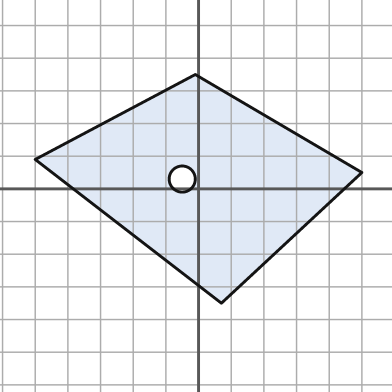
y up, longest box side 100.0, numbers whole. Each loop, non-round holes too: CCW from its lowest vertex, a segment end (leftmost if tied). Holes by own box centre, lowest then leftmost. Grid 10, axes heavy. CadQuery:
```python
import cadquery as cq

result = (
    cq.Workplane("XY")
    .moveTo(7.0, -35.0)
    .lineTo(50.0, 5.0)
    .lineTo(-1.0, 35.0)
    .lineTo(-50.0, 9.0)
    .close()
    .moveTo(-5.0, 3.0)
    .circle(4.0)
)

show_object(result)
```